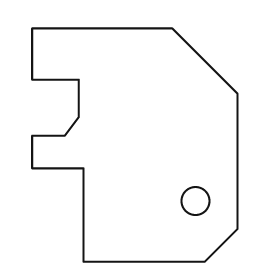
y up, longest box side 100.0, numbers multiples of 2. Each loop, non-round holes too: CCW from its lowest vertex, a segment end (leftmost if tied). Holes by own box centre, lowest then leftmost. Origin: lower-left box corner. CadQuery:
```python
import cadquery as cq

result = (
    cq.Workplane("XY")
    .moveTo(22.0, 0.0)
    .lineTo(74.0, 0.0)
    .lineTo(88.0, 14.0)
    .lineTo(88.0, 72.0)
    .lineTo(60.0, 100.0)
    .lineTo(0.0, 100.0)
    .lineTo(0.0, 78.0)
    .lineTo(20.0, 78.0)
    .lineTo(20.0, 62.0)
    .lineTo(14.0, 54.0)
    .lineTo(0.0, 54.0)
    .lineTo(0.0, 40.0)
    .lineTo(22.0, 40.0)
    .close()
    .moveTo(70.0, 26.0)
    .circle(6.0)
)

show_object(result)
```